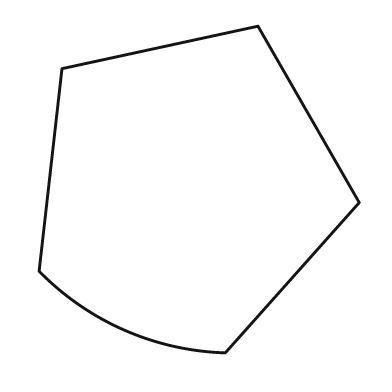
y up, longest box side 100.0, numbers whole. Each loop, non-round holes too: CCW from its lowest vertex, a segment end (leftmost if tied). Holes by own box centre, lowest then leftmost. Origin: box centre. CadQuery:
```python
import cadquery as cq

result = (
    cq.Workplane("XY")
    .moveTo(8.0, -50.0)
    .lineTo(49.0, -4.0)
    .lineTo(18.0, 50.0)
    .lineTo(-42.0, 37.0)
    .lineTo(-49.0, -25.0)
    .threePointArc((-23.0, -43.0), (8.0, -50.0))
    .close()
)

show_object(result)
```